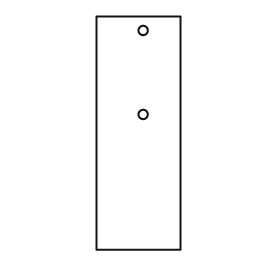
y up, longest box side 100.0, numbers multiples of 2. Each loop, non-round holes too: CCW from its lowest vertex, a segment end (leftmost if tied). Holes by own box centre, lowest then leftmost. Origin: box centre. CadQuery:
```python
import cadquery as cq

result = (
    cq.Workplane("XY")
    .moveTo(-18.0, -50.0)
    .lineTo(18.0, -50.0)
    .lineTo(18.0, 50.0)
    .lineTo(-18.0, 50.0)
    .close()
    .moveTo(2.0, 8.0)
    .circle(2.0)
    .moveTo(2.0, 44.0)
    .circle(2.0)
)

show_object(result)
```